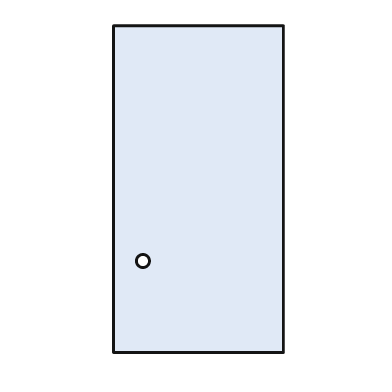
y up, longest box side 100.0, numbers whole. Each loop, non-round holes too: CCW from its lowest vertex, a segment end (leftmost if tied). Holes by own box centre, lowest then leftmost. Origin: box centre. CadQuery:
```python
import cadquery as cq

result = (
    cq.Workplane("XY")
    .moveTo(-26.0, -50.0)
    .lineTo(26.0, -50.0)
    .lineTo(26.0, 50.0)
    .lineTo(-26.0, 50.0)
    .close()
    .moveTo(-17.0, -22.0)
    .circle(2.0)
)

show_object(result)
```